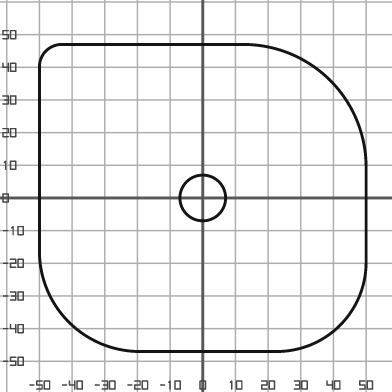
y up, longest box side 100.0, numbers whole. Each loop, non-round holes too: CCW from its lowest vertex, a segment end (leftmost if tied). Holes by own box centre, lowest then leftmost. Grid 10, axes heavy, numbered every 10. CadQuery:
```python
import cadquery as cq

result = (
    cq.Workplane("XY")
    .moveTo(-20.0, -47.0)
    .lineTo(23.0, -47.0)
    .threePointArc((42.0, -39.0), (50.0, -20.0))
    .lineTo(50.0, 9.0)
    .threePointArc((39.0, 36.0), (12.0, 47.0))
    .lineTo(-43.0, 47.0)
    .threePointArc((-48.0, 45.0), (-50.0, 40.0))
    .lineTo(-50.0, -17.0)
    .threePointArc((-41.0, -38.0), (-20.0, -47.0))
    .close()
    .moveTo(0.0, 0.0)
    .circle(7.0)
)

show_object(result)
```